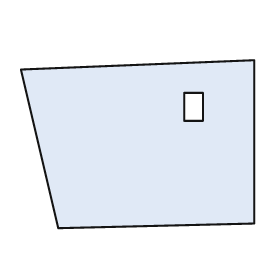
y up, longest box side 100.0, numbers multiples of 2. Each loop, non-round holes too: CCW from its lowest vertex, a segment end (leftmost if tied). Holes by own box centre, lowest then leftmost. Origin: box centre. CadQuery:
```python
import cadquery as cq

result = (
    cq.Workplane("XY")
    .moveTo(-34.0, -36.0)
    .lineTo(50.0, -34.0)
    .lineTo(50.0, 36.0)
    .lineTo(-50.0, 32.0)
    .close()
    .moveTo(20.0, 10.0)
    .lineTo(28.0, 10.0)
    .lineTo(28.0, 22.0)
    .lineTo(20.0, 22.0)
    .close()
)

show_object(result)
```